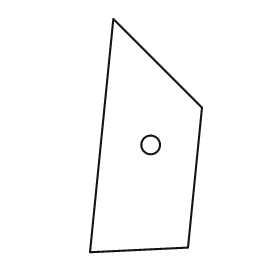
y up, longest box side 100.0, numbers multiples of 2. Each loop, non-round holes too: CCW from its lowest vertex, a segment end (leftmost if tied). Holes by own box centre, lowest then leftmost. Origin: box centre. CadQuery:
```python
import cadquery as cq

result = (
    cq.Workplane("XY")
    .moveTo(-24.0, -50.0)
    .lineTo(18.0, -48.0)
    .lineTo(24.0, 12.0)
    .lineTo(-14.0, 50.0)
    .close()
    .moveTo(2.0, -4.0)
    .circle(4.0)
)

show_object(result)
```